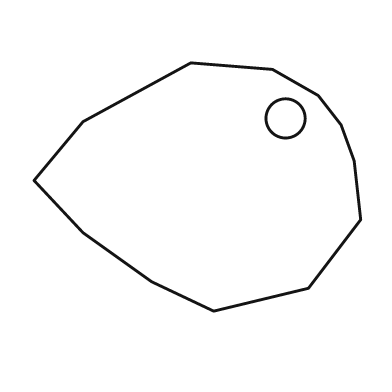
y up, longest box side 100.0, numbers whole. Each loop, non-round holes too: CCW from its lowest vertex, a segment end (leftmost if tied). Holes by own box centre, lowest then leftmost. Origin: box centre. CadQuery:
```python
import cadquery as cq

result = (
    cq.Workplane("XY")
    .moveTo(5.0, -38.0)
    .lineTo(34.0, -31.0)
    .lineTo(50.0, -10.0)
    .lineTo(48.0, 8.0)
    .lineTo(44.0, 19.0)
    .lineTo(37.0, 28.0)
    .lineTo(23.0, 36.0)
    .lineTo(-2.0, 38.0)
    .lineTo(-35.0, 20.0)
    .lineTo(-50.0, 2.0)
    .lineTo(-35.0, -14.0)
    .lineTo(-14.0, -29.0)
    .close()
    .moveTo(27.0, 21.0)
    .circle(6.0)
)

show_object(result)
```